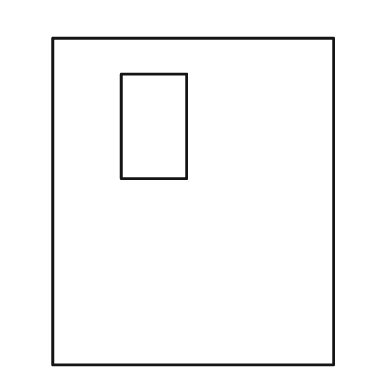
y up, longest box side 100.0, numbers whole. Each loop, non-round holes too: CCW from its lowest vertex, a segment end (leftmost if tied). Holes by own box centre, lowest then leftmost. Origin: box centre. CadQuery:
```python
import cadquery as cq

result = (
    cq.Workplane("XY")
    .moveTo(-43.0, -50.0)
    .lineTo(43.0, -50.0)
    .lineTo(43.0, 50.0)
    .lineTo(-43.0, 50.0)
    .close()
    .moveTo(-22.0, 7.0)
    .lineTo(-2.0, 7.0)
    .lineTo(-2.0, 39.0)
    .lineTo(-22.0, 39.0)
    .close()
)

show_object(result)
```